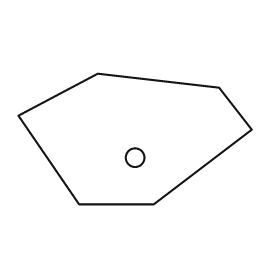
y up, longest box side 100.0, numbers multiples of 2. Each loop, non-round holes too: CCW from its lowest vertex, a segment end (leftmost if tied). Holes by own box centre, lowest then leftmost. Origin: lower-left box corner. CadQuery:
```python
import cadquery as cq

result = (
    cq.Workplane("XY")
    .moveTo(26.0, 0.0)
    .lineTo(58.0, 0.0)
    .lineTo(100.0, 32.0)
    .lineTo(86.0, 50.0)
    .lineTo(34.0, 56.0)
    .lineTo(0.0, 38.0)
    .close()
    .moveTo(50.0, 20.0)
    .circle(4.0)
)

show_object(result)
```